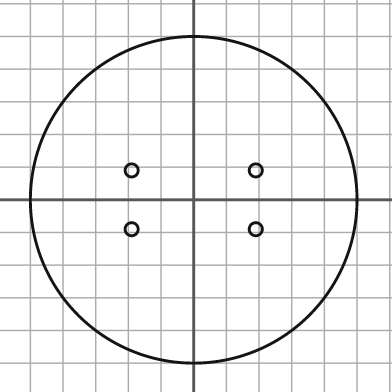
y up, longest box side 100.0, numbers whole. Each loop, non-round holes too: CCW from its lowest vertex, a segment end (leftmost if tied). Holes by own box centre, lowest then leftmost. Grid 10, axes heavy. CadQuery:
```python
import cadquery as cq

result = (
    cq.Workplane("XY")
    .moveTo(0.0, 0.0)
    .circle(50.0)
    .moveTo(-19.0, -9.0)
    .circle(2.0)
    .moveTo(19.0, -9.0)
    .circle(2.0)
    .moveTo(-19.0, 9.0)
    .circle(2.0)
    .moveTo(19.0, 9.0)
    .circle(2.0)
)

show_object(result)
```